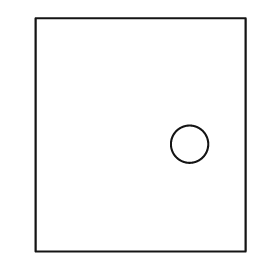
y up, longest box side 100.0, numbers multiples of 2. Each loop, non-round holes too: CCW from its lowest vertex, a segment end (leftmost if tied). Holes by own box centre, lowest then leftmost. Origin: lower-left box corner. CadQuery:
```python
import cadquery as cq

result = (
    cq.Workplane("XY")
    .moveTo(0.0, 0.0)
    .lineTo(90.0, 0.0)
    .lineTo(90.0, 100.0)
    .lineTo(0.0, 100.0)
    .close()
    .moveTo(66.0, 46.0)
    .circle(8.0)
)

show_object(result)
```